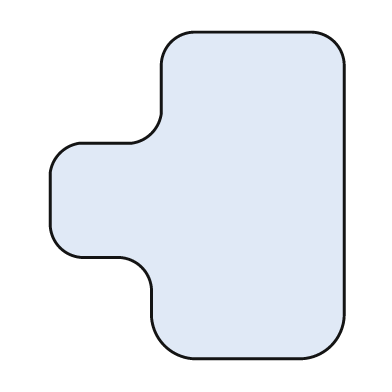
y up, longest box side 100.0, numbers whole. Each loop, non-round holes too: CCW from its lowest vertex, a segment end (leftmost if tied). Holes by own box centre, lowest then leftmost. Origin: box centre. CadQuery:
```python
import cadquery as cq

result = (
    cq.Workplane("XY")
    .moveTo(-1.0, -50.0)
    .lineTo(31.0, -50.0)
    .threePointArc((41.0, -46.0), (45.0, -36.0))
    .lineTo(45.0, 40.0)
    .threePointArc((42.0, 47.0), (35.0, 50.0))
    .lineTo(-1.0, 50.0)
    .threePointArc((-8.0, 47.0), (-11.0, 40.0))
    .lineTo(-11.0, 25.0)
    .threePointArc((-14.0, 19.0), (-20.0, 16.0))
    .lineTo(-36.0, 16.0)
    .threePointArc((-42.0, 13.0), (-45.0, 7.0))
    .lineTo(-45.0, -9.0)
    .threePointArc((-42.0, -16.0), (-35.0, -19.0))
    .lineTo(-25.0, -19.0)
    .threePointArc((-17.0, -22.0), (-14.0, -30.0))
    .lineTo(-14.0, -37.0)
    .threePointArc((-10.0, -46.0), (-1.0, -50.0))
    .close()
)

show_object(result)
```